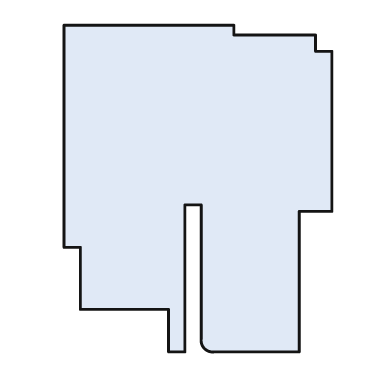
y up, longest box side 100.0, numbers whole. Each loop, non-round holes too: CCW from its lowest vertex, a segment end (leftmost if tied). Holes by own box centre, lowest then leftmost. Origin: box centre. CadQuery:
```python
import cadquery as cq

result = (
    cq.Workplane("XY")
    .moveTo(-9.0, -50.0)
    .lineTo(-4.0, -50.0)
    .lineTo(-4.0, -5.0)
    .lineTo(1.0, -5.0)
    .lineTo(1.0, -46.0)
    .threePointArc((2.0, -49.0), (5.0, -50.0))
    .lineTo(31.0, -50.0)
    .lineTo(31.0, -7.0)
    .lineTo(41.0, -7.0)
    .lineTo(41.0, 42.0)
    .lineTo(36.0, 42.0)
    .lineTo(36.0, 47.0)
    .lineTo(11.0, 47.0)
    .lineTo(11.0, 50.0)
    .lineTo(-41.0, 50.0)
    .lineTo(-41.0, -18.0)
    .lineTo(-36.0, -18.0)
    .lineTo(-36.0, -37.0)
    .lineTo(-9.0, -37.0)
    .close()
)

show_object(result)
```